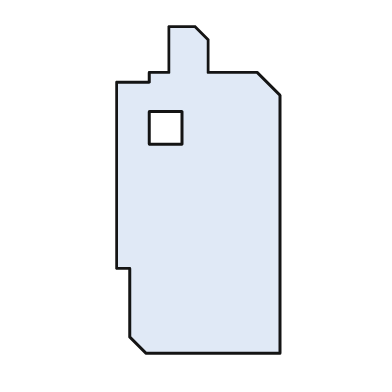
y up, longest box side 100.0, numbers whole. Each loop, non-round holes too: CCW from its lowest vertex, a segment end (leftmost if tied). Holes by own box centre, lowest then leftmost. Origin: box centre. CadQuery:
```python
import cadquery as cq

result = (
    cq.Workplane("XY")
    .moveTo(-16.0, -50.0)
    .lineTo(25.0, -50.0)
    .lineTo(25.0, 29.0)
    .lineTo(18.0, 36.0)
    .lineTo(3.0, 36.0)
    .lineTo(3.0, 46.0)
    .lineTo(-1.0, 50.0)
    .lineTo(-9.0, 50.0)
    .lineTo(-9.0, 36.0)
    .lineTo(-15.0, 36.0)
    .lineTo(-15.0, 33.0)
    .lineTo(-25.0, 33.0)
    .lineTo(-25.0, -24.0)
    .lineTo(-21.0, -24.0)
    .lineTo(-21.0, -45.0)
    .close()
    .moveTo(-15.0, 14.0)
    .lineTo(-5.0, 14.0)
    .lineTo(-5.0, 24.0)
    .lineTo(-15.0, 24.0)
    .close()
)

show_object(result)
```